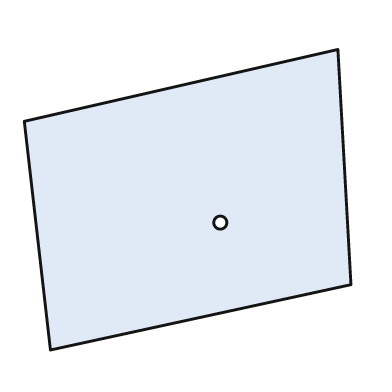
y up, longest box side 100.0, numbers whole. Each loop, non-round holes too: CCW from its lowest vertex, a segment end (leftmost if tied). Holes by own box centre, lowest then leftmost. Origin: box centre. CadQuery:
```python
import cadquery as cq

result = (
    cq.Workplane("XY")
    .moveTo(-42.0, -46.0)
    .lineTo(50.0, -26.0)
    .lineTo(46.0, 46.0)
    .lineTo(-50.0, 24.0)
    .close()
    .moveTo(10.0, -7.0)
    .circle(2.0)
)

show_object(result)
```